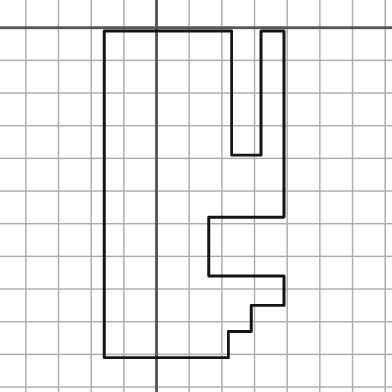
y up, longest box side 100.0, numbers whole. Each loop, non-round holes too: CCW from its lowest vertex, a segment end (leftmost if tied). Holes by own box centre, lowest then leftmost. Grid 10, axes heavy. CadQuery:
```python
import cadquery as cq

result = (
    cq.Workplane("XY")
    .moveTo(-16.0, -101.0)
    .lineTo(22.0, -101.0)
    .lineTo(22.0, -93.0)
    .lineTo(29.0, -93.0)
    .lineTo(29.0, -85.0)
    .lineTo(39.0, -85.0)
    .lineTo(39.0, -76.0)
    .lineTo(16.0, -76.0)
    .lineTo(16.0, -58.0)
    .lineTo(39.0, -58.0)
    .lineTo(39.0, -1.0)
    .lineTo(32.0, -1.0)
    .lineTo(32.0, -39.0)
    .lineTo(23.0, -39.0)
    .lineTo(23.0, -1.0)
    .lineTo(-16.0, -1.0)
    .close()
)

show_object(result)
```